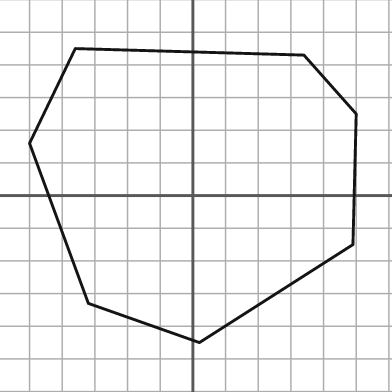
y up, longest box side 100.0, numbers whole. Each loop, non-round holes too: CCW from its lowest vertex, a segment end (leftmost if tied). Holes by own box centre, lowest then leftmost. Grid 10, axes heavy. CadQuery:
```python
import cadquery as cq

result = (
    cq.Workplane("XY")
    .moveTo(2.0, -45.0)
    .lineTo(49.0, -15.0)
    .lineTo(50.0, 25.0)
    .lineTo(34.0, 43.0)
    .lineTo(-36.0, 45.0)
    .lineTo(-50.0, 16.0)
    .lineTo(-32.0, -33.0)
    .close()
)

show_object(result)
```